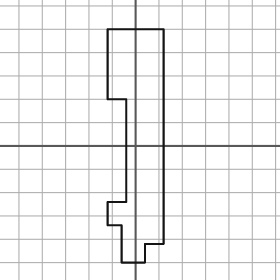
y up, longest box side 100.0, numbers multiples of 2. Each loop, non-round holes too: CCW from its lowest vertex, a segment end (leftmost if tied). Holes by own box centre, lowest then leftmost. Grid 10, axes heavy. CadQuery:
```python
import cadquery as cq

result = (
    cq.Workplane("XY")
    .moveTo(-6.0, -50.0)
    .lineTo(4.0, -50.0)
    .lineTo(4.0, -42.0)
    .lineTo(12.0, -42.0)
    .lineTo(12.0, 50.0)
    .lineTo(-12.0, 50.0)
    .lineTo(-12.0, 20.0)
    .lineTo(-4.0, 20.0)
    .lineTo(-4.0, -24.0)
    .lineTo(-12.0, -24.0)
    .lineTo(-12.0, -34.0)
    .lineTo(-6.0, -34.0)
    .close()
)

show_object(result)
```